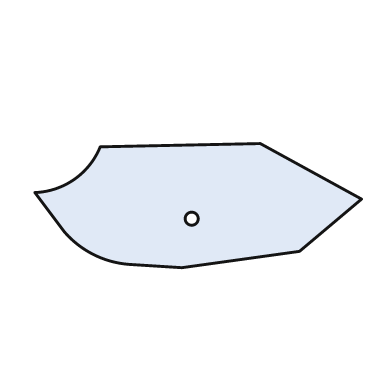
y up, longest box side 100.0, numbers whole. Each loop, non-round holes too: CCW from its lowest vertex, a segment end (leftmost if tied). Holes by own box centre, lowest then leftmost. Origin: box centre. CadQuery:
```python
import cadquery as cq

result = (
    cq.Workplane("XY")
    .moveTo(-5.0, -19.0)
    .lineTo(31.0, -14.0)
    .lineTo(50.0, 2.0)
    .lineTo(19.0, 19.0)
    .lineTo(-30.0, 18.0)
    .threePointArc((-38.0, 8.0), (-50.0, 4.0))
    .lineTo(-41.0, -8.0)
    .threePointArc((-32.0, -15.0), (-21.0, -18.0))
    .close()
    .moveTo(-2.0, -4.0)
    .circle(2.0)
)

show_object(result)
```